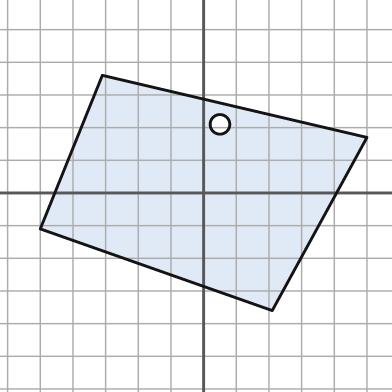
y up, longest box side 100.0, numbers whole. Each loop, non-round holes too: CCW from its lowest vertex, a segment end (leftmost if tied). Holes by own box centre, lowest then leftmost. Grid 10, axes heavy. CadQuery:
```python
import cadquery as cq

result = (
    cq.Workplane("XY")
    .moveTo(21.0, -36.0)
    .lineTo(50.0, 17.0)
    .lineTo(-31.0, 36.0)
    .lineTo(-50.0, -11.0)
    .close()
    .moveTo(5.0, 21.0)
    .circle(3.0)
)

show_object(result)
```